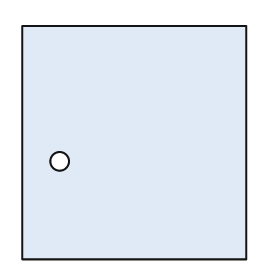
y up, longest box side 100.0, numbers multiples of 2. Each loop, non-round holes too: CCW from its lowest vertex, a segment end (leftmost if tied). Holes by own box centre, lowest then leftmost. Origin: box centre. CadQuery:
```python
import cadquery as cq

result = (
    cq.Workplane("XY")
    .moveTo(-48.0, -50.0)
    .lineTo(48.0, -50.0)
    .lineTo(48.0, 50.0)
    .lineTo(-48.0, 50.0)
    .close()
    .moveTo(-32.0, -8.0)
    .circle(4.0)
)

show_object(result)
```